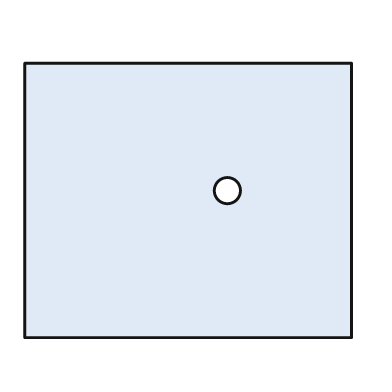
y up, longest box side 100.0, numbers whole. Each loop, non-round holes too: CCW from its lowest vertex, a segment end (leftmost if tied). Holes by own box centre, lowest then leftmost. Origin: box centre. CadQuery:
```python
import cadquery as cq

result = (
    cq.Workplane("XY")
    .moveTo(-50.0, -42.0)
    .lineTo(50.0, -42.0)
    .lineTo(50.0, 42.0)
    .lineTo(-50.0, 42.0)
    .close()
    .moveTo(12.0, 3.0)
    .circle(4.0)
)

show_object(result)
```